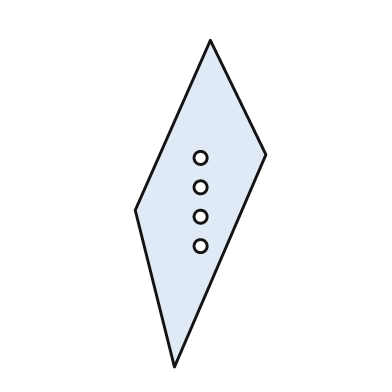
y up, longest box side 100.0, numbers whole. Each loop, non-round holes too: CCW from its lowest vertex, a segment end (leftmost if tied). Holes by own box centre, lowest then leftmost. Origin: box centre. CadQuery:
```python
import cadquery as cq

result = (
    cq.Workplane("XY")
    .moveTo(-8.0, -50.0)
    .lineTo(20.0, 15.0)
    .lineTo(3.0, 50.0)
    .lineTo(-20.0, -2.0)
    .close()
    .moveTo(0.0, -13.0)
    .circle(2.0)
    .moveTo(0.0, -4.0)
    .circle(2.0)
    .moveTo(0.0, 5.0)
    .circle(2.0)
    .moveTo(0.0, 14.0)
    .circle(2.0)
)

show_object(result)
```